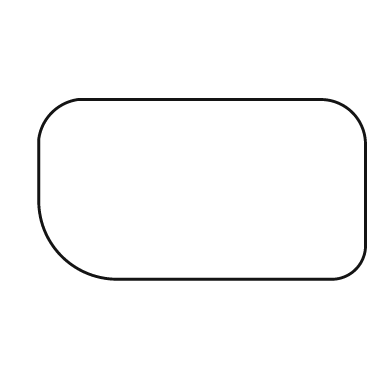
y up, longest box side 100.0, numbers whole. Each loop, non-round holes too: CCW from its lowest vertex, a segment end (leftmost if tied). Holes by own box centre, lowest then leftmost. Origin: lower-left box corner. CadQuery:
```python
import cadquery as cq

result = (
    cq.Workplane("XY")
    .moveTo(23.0, 0.0)
    .lineTo(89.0, 0.0)
    .threePointArc((97.0, 3.0), (100.0, 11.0))
    .lineTo(100.0, 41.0)
    .threePointArc((96.0, 51.0), (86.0, 55.0))
    .lineTo(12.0, 55.0)
    .threePointArc((4.0, 51.0), (0.0, 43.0))
    .lineTo(0.0, 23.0)
    .threePointArc((7.0, 7.0), (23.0, 0.0))
    .close()
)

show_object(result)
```